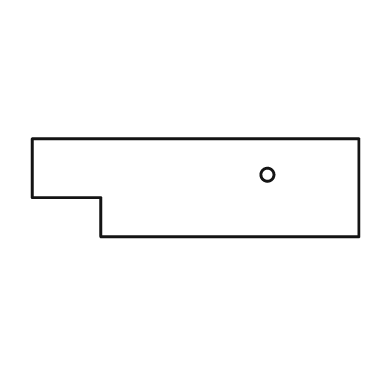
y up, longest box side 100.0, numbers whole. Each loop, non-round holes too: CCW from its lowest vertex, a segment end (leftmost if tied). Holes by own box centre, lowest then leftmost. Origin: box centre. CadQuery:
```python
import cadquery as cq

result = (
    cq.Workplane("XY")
    .moveTo(-29.0, -15.0)
    .lineTo(50.0, -15.0)
    .lineTo(50.0, 15.0)
    .lineTo(-50.0, 15.0)
    .lineTo(-50.0, -3.0)
    .lineTo(-29.0, -3.0)
    .close()
    .moveTo(22.0, 4.0)
    .circle(2.0)
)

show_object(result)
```